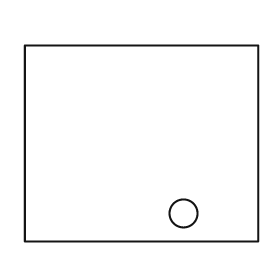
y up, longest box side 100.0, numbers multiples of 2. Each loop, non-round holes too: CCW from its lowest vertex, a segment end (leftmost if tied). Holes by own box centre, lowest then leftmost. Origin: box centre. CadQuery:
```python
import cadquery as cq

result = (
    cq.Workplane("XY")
    .moveTo(-50.0, -42.0)
    .lineTo(50.0, -42.0)
    .lineTo(50.0, 42.0)
    .lineTo(-50.0, 42.0)
    .close()
    .moveTo(18.0, -30.0)
    .circle(6.0)
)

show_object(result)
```